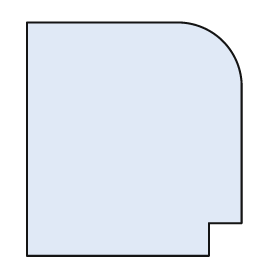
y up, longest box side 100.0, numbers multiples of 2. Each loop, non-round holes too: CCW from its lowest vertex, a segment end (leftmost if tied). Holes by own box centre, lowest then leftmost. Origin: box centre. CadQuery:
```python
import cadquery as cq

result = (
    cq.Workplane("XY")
    .moveTo(-46.0, -50.0)
    .lineTo(32.0, -50.0)
    .lineTo(32.0, -36.0)
    .lineTo(46.0, -36.0)
    .lineTo(46.0, 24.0)
    .threePointArc((38.0, 42.0), (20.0, 50.0))
    .lineTo(-46.0, 50.0)
    .close()
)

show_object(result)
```